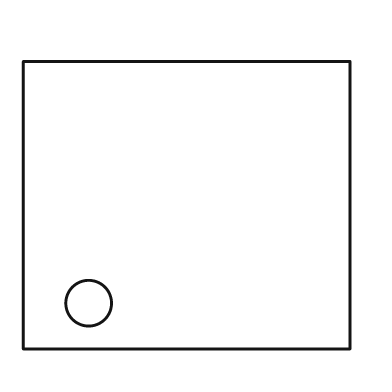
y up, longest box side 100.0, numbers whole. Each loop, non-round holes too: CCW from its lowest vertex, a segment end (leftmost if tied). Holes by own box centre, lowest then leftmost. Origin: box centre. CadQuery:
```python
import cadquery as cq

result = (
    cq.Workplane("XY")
    .moveTo(-50.0, -44.0)
    .lineTo(50.0, -44.0)
    .lineTo(50.0, 44.0)
    .lineTo(-50.0, 44.0)
    .close()
    .moveTo(-30.0, -30.0)
    .circle(7.0)
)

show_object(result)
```